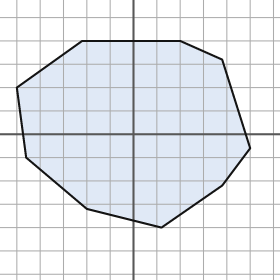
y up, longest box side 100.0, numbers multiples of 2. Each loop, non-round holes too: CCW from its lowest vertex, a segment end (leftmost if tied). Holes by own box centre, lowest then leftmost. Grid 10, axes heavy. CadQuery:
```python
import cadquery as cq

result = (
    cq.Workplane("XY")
    .moveTo(12.0, -40.0)
    .lineTo(38.0, -22.0)
    .lineTo(50.0, -6.0)
    .lineTo(38.0, 32.0)
    .lineTo(20.0, 40.0)
    .lineTo(-22.0, 40.0)
    .lineTo(-50.0, 20.0)
    .lineTo(-46.0, -10.0)
    .lineTo(-20.0, -32.0)
    .close()
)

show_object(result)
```